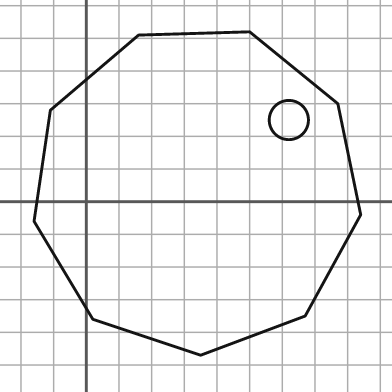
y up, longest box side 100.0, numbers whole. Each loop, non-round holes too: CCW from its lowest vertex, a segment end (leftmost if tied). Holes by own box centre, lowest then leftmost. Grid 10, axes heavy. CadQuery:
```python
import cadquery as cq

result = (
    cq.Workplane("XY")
    .moveTo(35.0, -47.0)
    .lineTo(67.0, -35.0)
    .lineTo(84.0, -4.0)
    .lineTo(77.0, 30.0)
    .lineTo(50.0, 52.0)
    .lineTo(16.0, 51.0)
    .lineTo(-11.0, 28.0)
    .lineTo(-16.0, -6.0)
    .lineTo(2.0, -36.0)
    .close()
    .moveTo(62.0, 25.0)
    .circle(6.0)
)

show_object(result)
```